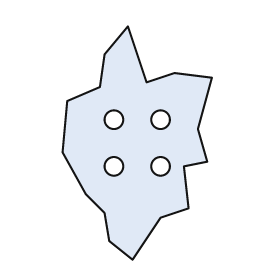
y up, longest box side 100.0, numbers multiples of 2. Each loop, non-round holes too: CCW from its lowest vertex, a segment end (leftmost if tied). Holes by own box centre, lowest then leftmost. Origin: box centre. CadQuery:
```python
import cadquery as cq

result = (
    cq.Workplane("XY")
    .moveTo(-2.0, -50.0)
    .lineTo(10.0, -32.0)
    .lineTo(22.0, -28.0)
    .lineTo(20.0, -10.0)
    .lineTo(30.0, -8.0)
    .lineTo(26.0, 6.0)
    .lineTo(32.0, 28.0)
    .lineTo(16.0, 30.0)
    .lineTo(4.0, 26.0)
    .lineTo(-4.0, 50.0)
    .lineTo(-14.0, 38.0)
    .lineTo(-16.0, 24.0)
    .lineTo(-30.0, 18.0)
    .lineTo(-32.0, -4.0)
    .lineTo(-22.0, -22.0)
    .lineTo(-14.0, -30.0)
    .lineTo(-12.0, -42.0)
    .close()
    .moveTo(-10.0, -10.0)
    .circle(4.0)
    .moveTo(10.0, -10.0)
    .circle(4.0)
    .moveTo(-10.0, 10.0)
    .circle(4.0)
    .moveTo(10.0, 10.0)
    .circle(4.0)
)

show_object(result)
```